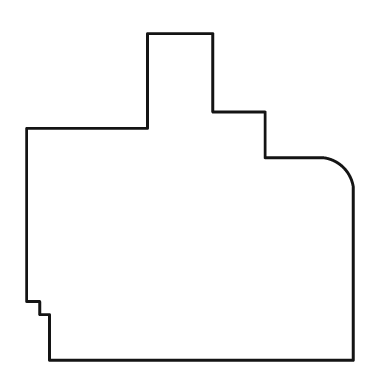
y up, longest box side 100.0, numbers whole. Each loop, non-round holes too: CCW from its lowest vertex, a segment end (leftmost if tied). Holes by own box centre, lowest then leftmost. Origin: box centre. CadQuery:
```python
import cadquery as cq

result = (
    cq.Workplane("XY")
    .moveTo(-43.0, -50.0)
    .lineTo(50.0, -50.0)
    .lineTo(50.0, 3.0)
    .threePointArc((47.0, 9.0), (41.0, 12.0))
    .lineTo(23.0, 12.0)
    .lineTo(23.0, 26.0)
    .lineTo(7.0, 26.0)
    .lineTo(7.0, 50.0)
    .lineTo(-13.0, 50.0)
    .lineTo(-13.0, 21.0)
    .lineTo(-50.0, 21.0)
    .lineTo(-50.0, -32.0)
    .lineTo(-46.0, -32.0)
    .lineTo(-46.0, -36.0)
    .lineTo(-43.0, -36.0)
    .close()
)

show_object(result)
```